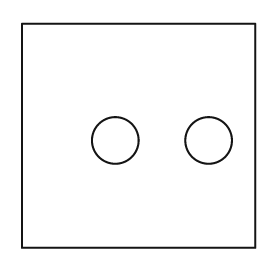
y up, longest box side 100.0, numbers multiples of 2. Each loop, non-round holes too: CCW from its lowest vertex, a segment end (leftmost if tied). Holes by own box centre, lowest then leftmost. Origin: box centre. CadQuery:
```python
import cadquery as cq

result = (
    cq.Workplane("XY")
    .moveTo(-50.0, -48.0)
    .lineTo(50.0, -48.0)
    .lineTo(50.0, 48.0)
    .lineTo(-50.0, 48.0)
    .close()
    .moveTo(-10.0, -2.0)
    .circle(10.0)
    .moveTo(30.0, -2.0)
    .circle(10.0)
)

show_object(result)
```